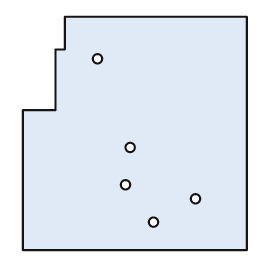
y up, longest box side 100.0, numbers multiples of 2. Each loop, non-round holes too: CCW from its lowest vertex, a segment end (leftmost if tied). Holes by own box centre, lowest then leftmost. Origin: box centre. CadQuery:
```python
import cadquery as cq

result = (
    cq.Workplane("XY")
    .moveTo(-48.0, -50.0)
    .lineTo(48.0, -50.0)
    .lineTo(48.0, 50.0)
    .lineTo(-30.0, 50.0)
    .lineTo(-30.0, 36.0)
    .lineTo(-34.0, 36.0)
    .lineTo(-34.0, 10.0)
    .lineTo(-48.0, 10.0)
    .close()
    .moveTo(8.0, -38.0)
    .circle(2.0)
    .moveTo(26.0, -28.0)
    .circle(2.0)
    .moveTo(-4.0, -22.0)
    .circle(2.0)
    .moveTo(-2.0, -6.0)
    .circle(2.0)
    .moveTo(-16.0, 32.0)
    .circle(2.0)
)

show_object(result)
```